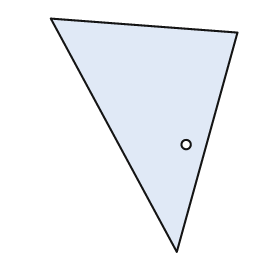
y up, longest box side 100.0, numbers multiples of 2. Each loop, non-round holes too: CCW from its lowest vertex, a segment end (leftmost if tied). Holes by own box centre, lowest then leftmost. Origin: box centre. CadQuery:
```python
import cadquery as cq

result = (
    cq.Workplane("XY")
    .moveTo(14.0, -50.0)
    .lineTo(40.0, 44.0)
    .lineTo(-40.0, 50.0)
    .close()
    .moveTo(18.0, -4.0)
    .circle(2.0)
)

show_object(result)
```